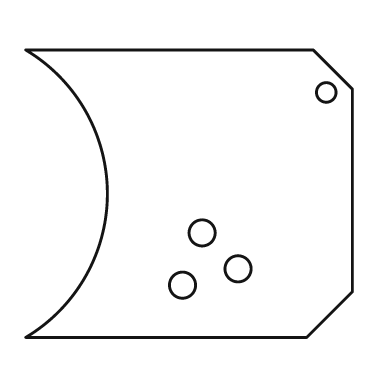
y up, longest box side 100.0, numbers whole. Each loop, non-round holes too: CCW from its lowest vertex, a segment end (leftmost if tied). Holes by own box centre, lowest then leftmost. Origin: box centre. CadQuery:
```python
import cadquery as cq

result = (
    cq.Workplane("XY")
    .moveTo(-50.0, -44.0)
    .lineTo(36.0, -44.0)
    .lineTo(50.0, -30.0)
    .lineTo(50.0, 32.0)
    .lineTo(38.0, 44.0)
    .lineTo(-50.0, 44.0)
    .threePointArc((-25.0, 0.0), (-50.0, -44.0))
    .close()
    .moveTo(-2.0, -28.0)
    .circle(4.0)
    .moveTo(15.0, -23.0)
    .circle(4.0)
    .moveTo(4.0, -12.0)
    .circle(4.0)
    .moveTo(42.0, 31.0)
    .circle(3.0)
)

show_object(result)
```